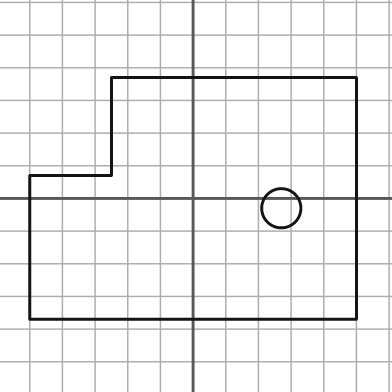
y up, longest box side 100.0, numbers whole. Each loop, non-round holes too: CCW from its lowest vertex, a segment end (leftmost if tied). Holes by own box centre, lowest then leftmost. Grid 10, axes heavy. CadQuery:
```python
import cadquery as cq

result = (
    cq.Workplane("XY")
    .moveTo(-50.0, -37.0)
    .lineTo(50.0, -37.0)
    .lineTo(50.0, 37.0)
    .lineTo(-25.0, 37.0)
    .lineTo(-25.0, 7.0)
    .lineTo(-50.0, 7.0)
    .close()
    .moveTo(27.0, -3.0)
    .circle(6.0)
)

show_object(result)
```